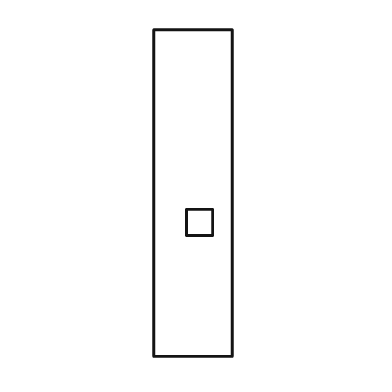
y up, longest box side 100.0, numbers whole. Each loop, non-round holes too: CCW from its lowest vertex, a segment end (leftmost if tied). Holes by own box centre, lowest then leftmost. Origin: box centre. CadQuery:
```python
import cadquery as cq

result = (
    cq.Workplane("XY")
    .moveTo(-12.0, -50.0)
    .lineTo(12.0, -50.0)
    .lineTo(12.0, 50.0)
    .lineTo(-12.0, 50.0)
    .close()
    .moveTo(-2.0, -13.0)
    .lineTo(6.0, -13.0)
    .lineTo(6.0, -5.0)
    .lineTo(-2.0, -5.0)
    .close()
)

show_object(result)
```